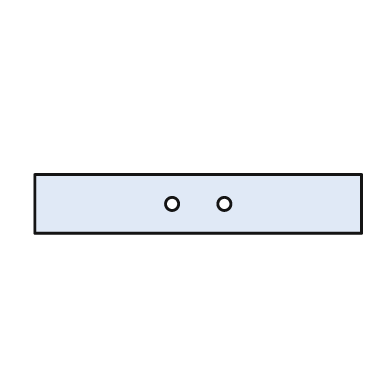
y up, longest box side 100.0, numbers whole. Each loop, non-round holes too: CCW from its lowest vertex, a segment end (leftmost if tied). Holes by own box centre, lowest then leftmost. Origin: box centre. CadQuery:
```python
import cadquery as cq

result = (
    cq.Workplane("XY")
    .moveTo(-50.0, -9.0)
    .lineTo(50.0, -9.0)
    .lineTo(50.0, 9.0)
    .lineTo(-50.0, 9.0)
    .close()
    .moveTo(-8.0, 0.0)
    .circle(2.0)
    .moveTo(8.0, 0.0)
    .circle(2.0)
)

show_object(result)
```